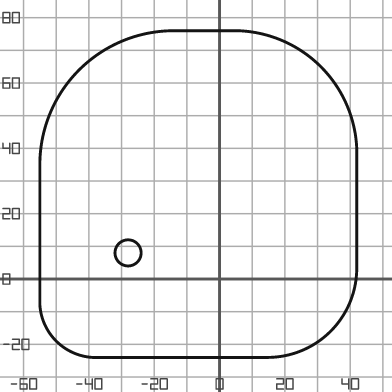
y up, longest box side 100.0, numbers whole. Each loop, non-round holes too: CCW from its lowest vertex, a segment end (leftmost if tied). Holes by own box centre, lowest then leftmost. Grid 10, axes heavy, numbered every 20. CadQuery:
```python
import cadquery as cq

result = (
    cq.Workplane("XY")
    .moveTo(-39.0, -24.0)
    .lineTo(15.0, -24.0)
    .threePointArc((34.0, -16.0), (42.0, 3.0))
    .lineTo(42.0, 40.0)
    .threePointArc((31.0, 65.0), (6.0, 76.0))
    .lineTo(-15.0, 76.0)
    .threePointArc((-43.0, 64.0), (-55.0, 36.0))
    .lineTo(-55.0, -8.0)
    .threePointArc((-50.0, -19.0), (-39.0, -24.0))
    .close()
    .moveTo(-28.0, 8.0)
    .circle(4.0)
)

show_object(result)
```